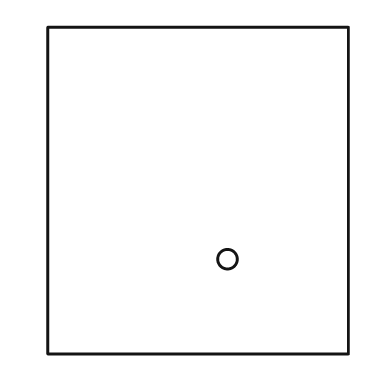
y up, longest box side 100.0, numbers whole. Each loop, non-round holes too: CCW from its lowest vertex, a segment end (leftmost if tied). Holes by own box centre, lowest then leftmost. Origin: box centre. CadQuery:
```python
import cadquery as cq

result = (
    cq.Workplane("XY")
    .moveTo(-46.0, -50.0)
    .lineTo(46.0, -50.0)
    .lineTo(46.0, 50.0)
    .lineTo(-46.0, 50.0)
    .close()
    .moveTo(9.0, -21.0)
    .circle(3.0)
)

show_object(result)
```